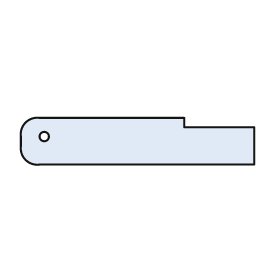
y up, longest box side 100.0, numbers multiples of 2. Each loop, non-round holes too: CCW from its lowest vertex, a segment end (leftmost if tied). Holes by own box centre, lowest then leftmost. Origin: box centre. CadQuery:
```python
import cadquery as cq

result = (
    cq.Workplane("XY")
    .moveTo(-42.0, -10.0)
    .lineTo(50.0, -10.0)
    .lineTo(50.0, 6.0)
    .lineTo(20.0, 6.0)
    .lineTo(20.0, 10.0)
    .lineTo(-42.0, 10.0)
    .threePointArc((-48.0, 8.0), (-50.0, 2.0))
    .lineTo(-50.0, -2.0)
    .threePointArc((-48.0, -8.0), (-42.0, -10.0))
    .close()
    .moveTo(-40.0, 2.0)
    .circle(2.0)
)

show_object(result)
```